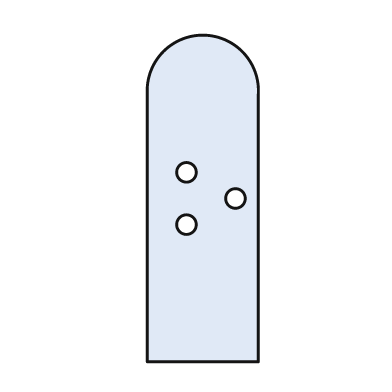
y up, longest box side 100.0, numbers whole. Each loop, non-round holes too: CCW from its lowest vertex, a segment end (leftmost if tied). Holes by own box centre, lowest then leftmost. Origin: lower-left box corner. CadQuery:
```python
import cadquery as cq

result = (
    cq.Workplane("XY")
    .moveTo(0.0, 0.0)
    .lineTo(34.0, 0.0)
    .lineTo(34.0, 82.0)
    .threePointArc((17.0, 100.0), (0.0, 82.0))
    .close()
    .moveTo(12.0, 42.0)
    .circle(3.0)
    .moveTo(27.0, 50.0)
    .circle(3.0)
    .moveTo(12.0, 58.0)
    .circle(3.0)
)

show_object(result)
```